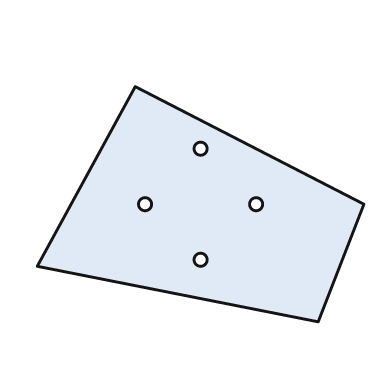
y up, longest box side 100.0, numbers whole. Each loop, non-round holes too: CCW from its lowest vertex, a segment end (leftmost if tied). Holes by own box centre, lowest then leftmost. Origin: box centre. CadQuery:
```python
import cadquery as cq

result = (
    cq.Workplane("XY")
    .moveTo(36.0, -36.0)
    .lineTo(50.0, 0.0)
    .lineTo(-20.0, 36.0)
    .lineTo(-50.0, -19.0)
    .close()
    .moveTo(0.0, -17.0)
    .circle(2.0)
    .moveTo(-17.0, 0.0)
    .circle(2.0)
    .moveTo(17.0, 0.0)
    .circle(2.0)
    .moveTo(0.0, 17.0)
    .circle(2.0)
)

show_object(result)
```